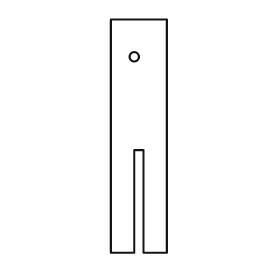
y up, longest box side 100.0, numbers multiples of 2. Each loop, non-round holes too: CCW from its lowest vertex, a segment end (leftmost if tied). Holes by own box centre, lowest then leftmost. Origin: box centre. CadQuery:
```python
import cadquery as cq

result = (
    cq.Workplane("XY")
    .moveTo(-12.0, -50.0)
    .lineTo(-2.0, -50.0)
    .lineTo(-2.0, -6.0)
    .lineTo(2.0, -6.0)
    .lineTo(2.0, -50.0)
    .lineTo(12.0, -50.0)
    .lineTo(12.0, 50.0)
    .lineTo(-12.0, 50.0)
    .close()
    .moveTo(-2.0, 34.0)
    .circle(2.0)
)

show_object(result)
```